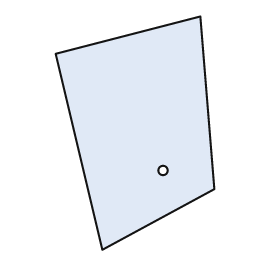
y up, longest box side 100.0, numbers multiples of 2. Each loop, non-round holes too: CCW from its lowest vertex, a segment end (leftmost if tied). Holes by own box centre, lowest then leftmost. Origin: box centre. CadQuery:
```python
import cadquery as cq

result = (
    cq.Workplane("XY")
    .moveTo(-14.0, -50.0)
    .lineTo(34.0, -24.0)
    .lineTo(28.0, 50.0)
    .lineTo(-34.0, 34.0)
    .close()
    .moveTo(12.0, -16.0)
    .circle(2.0)
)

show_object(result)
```